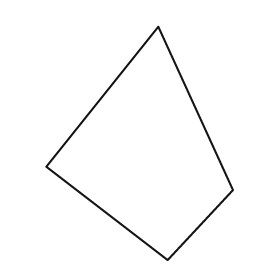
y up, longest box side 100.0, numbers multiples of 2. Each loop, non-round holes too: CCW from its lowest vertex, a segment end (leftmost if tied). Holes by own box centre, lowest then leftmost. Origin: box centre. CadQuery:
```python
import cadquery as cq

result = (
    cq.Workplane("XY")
    .moveTo(12.0, -50.0)
    .lineTo(40.0, -20.0)
    .lineTo(8.0, 50.0)
    .lineTo(-40.0, -10.0)
    .close()
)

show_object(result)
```